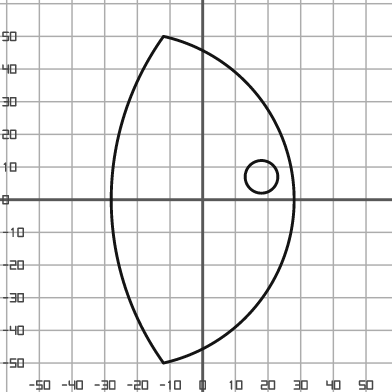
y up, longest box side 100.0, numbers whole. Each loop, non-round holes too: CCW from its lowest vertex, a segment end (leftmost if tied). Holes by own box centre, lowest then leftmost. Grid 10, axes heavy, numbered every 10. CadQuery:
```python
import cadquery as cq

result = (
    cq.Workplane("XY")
    .moveTo(-12.0, -50.0)
    .threePointArc((28.0, 0.0), (-12.0, 50.0))
    .threePointArc((-28.0, 0.0), (-12.0, -50.0))
    .close()
    .moveTo(18.0, 7.0)
    .circle(5.0)
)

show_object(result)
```